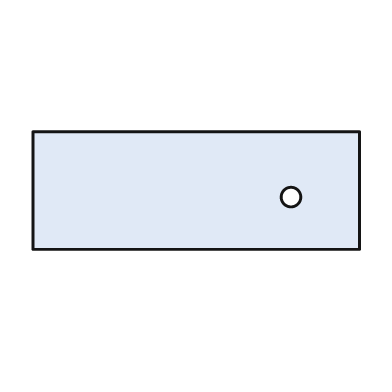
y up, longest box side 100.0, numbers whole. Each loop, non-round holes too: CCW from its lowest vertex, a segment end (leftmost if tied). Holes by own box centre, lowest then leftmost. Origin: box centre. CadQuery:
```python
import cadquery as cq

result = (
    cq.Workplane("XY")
    .moveTo(-50.0, -18.0)
    .lineTo(50.0, -18.0)
    .lineTo(50.0, 18.0)
    .lineTo(-50.0, 18.0)
    .close()
    .moveTo(29.0, -2.0)
    .circle(3.0)
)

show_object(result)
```